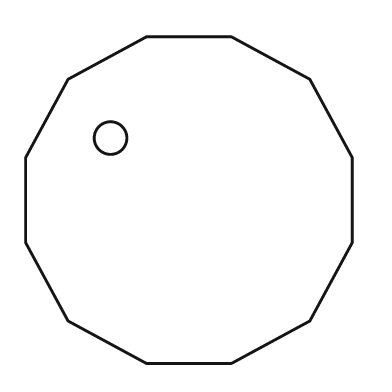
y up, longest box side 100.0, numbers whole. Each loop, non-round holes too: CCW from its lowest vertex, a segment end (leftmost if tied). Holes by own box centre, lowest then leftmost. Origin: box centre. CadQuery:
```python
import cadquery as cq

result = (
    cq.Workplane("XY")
    .moveTo(-13.0, -50.0)
    .lineTo(13.0, -50.0)
    .lineTo(37.0, -37.0)
    .lineTo(50.0, -13.0)
    .lineTo(50.0, 13.0)
    .lineTo(37.0, 37.0)
    .lineTo(13.0, 50.0)
    .lineTo(-13.0, 50.0)
    .lineTo(-37.0, 37.0)
    .lineTo(-50.0, 13.0)
    .lineTo(-50.0, -13.0)
    .lineTo(-37.0, -37.0)
    .close()
    .moveTo(-24.0, 19.0)
    .circle(5.0)
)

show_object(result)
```